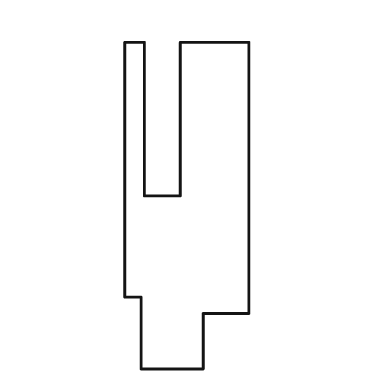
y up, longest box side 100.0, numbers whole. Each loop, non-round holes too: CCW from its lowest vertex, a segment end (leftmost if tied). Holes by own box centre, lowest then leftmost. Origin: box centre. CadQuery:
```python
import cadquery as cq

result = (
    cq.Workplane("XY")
    .moveTo(-14.0, -50.0)
    .lineTo(5.0, -50.0)
    .lineTo(5.0, -33.0)
    .lineTo(19.0, -33.0)
    .lineTo(19.0, 50.0)
    .lineTo(-2.0, 50.0)
    .lineTo(-2.0, 3.0)
    .lineTo(-13.0, 3.0)
    .lineTo(-13.0, 50.0)
    .lineTo(-19.0, 50.0)
    .lineTo(-19.0, -28.0)
    .lineTo(-14.0, -28.0)
    .close()
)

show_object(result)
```